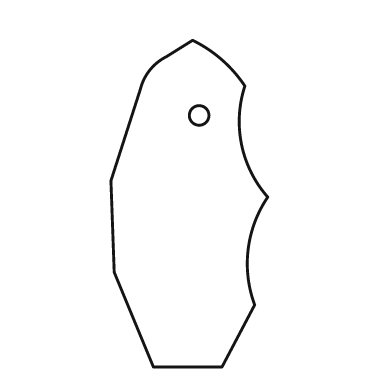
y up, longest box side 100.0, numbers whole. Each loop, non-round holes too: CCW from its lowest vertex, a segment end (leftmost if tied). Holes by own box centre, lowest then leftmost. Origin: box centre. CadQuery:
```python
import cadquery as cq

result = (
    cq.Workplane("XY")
    .moveTo(-11.0, -50.0)
    .lineTo(10.0, -50.0)
    .lineTo(20.0, -31.0)
    .threePointArc((18.0, -14.0), (24.0, 2.0))
    .threePointArc((16.0, 18.0), (17.0, 36.0))
    .threePointArc((10.0, 44.0), (1.0, 50.0))
    .lineTo(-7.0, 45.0)
    .threePointArc((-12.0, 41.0), (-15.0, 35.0))
    .lineTo(-24.0, 7.0)
    .lineTo(-23.0, -21.0)
    .close()
    .moveTo(3.0, 27.0)
    .circle(3.0)
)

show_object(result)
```